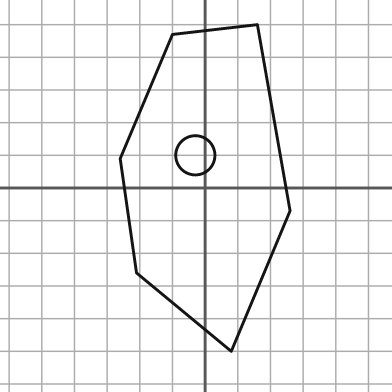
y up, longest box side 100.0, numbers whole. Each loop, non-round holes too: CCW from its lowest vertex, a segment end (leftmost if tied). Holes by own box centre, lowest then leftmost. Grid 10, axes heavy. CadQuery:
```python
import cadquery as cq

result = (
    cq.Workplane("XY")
    .moveTo(8.0, -50.0)
    .lineTo(26.0, -7.0)
    .lineTo(16.0, 50.0)
    .lineTo(-10.0, 47.0)
    .lineTo(-26.0, 9.0)
    .lineTo(-21.0, -26.0)
    .close()
    .moveTo(-3.0, 10.0)
    .circle(6.0)
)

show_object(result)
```